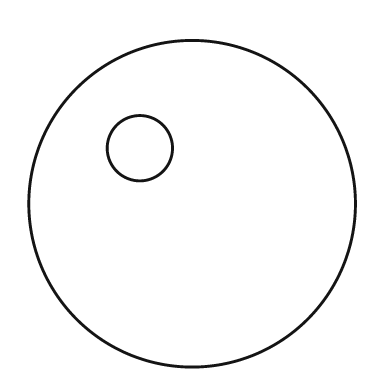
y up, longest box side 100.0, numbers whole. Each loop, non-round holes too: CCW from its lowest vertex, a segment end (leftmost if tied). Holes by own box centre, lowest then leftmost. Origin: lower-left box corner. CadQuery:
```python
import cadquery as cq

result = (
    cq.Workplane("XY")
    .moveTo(50.0, 50.0)
    .circle(50.0)
    .moveTo(34.0, 67.0)
    .circle(10.0)
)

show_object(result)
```